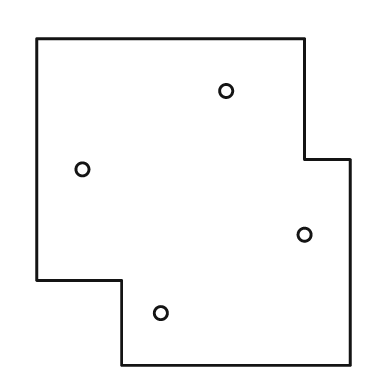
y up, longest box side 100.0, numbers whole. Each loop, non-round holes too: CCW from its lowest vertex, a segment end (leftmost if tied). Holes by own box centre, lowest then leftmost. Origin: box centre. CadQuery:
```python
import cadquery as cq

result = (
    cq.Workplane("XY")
    .moveTo(-22.0, -50.0)
    .lineTo(48.0, -50.0)
    .lineTo(48.0, 13.0)
    .lineTo(34.0, 13.0)
    .lineTo(34.0, 50.0)
    .lineTo(-48.0, 50.0)
    .lineTo(-48.0, -24.0)
    .lineTo(-22.0, -24.0)
    .close()
    .moveTo(-10.0, -34.0)
    .circle(2.0)
    .moveTo(34.0, -10.0)
    .circle(2.0)
    .moveTo(-34.0, 10.0)
    .circle(2.0)
    .moveTo(10.0, 34.0)
    .circle(2.0)
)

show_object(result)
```